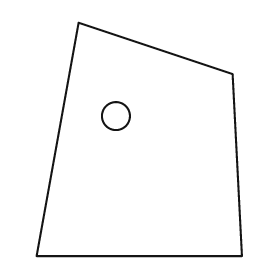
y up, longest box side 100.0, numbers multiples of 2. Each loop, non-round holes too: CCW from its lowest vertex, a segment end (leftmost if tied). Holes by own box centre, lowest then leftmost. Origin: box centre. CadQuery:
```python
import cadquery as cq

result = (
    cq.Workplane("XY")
    .moveTo(-44.0, -50.0)
    .lineTo(44.0, -50.0)
    .lineTo(40.0, 28.0)
    .lineTo(-26.0, 50.0)
    .close()
    .moveTo(-10.0, 10.0)
    .circle(6.0)
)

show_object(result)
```